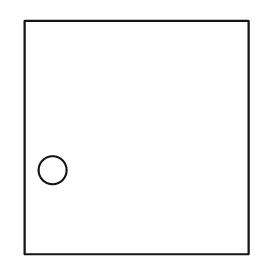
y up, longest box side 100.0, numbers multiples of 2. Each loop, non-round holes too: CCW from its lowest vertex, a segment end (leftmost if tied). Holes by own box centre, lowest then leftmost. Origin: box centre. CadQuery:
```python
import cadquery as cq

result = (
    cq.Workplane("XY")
    .moveTo(-48.0, -50.0)
    .lineTo(48.0, -50.0)
    .lineTo(48.0, 50.0)
    .lineTo(-48.0, 50.0)
    .close()
    .moveTo(-36.0, -14.0)
    .circle(6.0)
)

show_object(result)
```